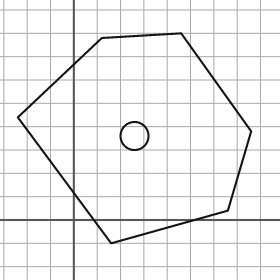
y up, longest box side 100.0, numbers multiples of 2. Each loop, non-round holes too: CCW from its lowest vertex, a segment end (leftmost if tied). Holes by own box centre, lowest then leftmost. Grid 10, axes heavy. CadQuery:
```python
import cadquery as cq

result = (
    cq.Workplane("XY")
    .moveTo(16.0, -10.0)
    .lineTo(66.0, 4.0)
    .lineTo(76.0, 38.0)
    .lineTo(46.0, 80.0)
    .lineTo(12.0, 78.0)
    .lineTo(-24.0, 44.0)
    .close()
    .moveTo(26.0, 36.0)
    .circle(6.0)
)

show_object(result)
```